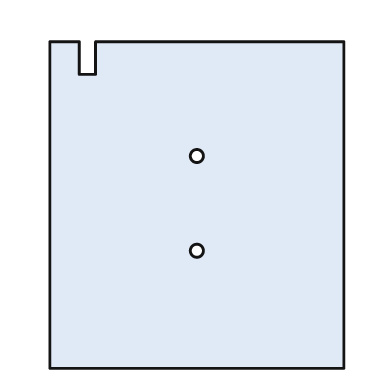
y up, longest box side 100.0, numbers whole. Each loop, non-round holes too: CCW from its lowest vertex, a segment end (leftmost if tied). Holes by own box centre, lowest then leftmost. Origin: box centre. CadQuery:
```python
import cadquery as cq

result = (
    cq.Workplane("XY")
    .moveTo(-45.0, -50.0)
    .lineTo(45.0, -50.0)
    .lineTo(45.0, 50.0)
    .lineTo(-31.0, 50.0)
    .lineTo(-31.0, 40.0)
    .lineTo(-36.0, 40.0)
    .lineTo(-36.0, 50.0)
    .lineTo(-45.0, 50.0)
    .close()
    .moveTo(0.0, -14.0)
    .circle(2.0)
    .moveTo(0.0, 15.0)
    .circle(2.0)
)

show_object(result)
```